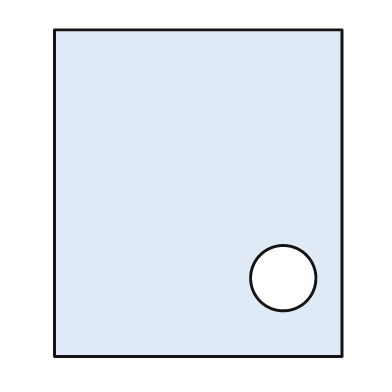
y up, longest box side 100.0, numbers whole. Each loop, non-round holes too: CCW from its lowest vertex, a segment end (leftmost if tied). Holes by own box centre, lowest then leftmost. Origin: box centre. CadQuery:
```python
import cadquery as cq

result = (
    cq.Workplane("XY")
    .moveTo(-44.0, -50.0)
    .lineTo(44.0, -50.0)
    .lineTo(44.0, 50.0)
    .lineTo(-44.0, 50.0)
    .close()
    .moveTo(26.0, -26.0)
    .circle(10.0)
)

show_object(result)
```